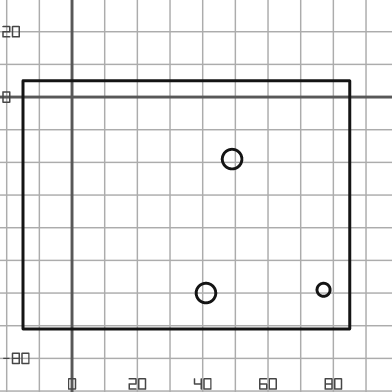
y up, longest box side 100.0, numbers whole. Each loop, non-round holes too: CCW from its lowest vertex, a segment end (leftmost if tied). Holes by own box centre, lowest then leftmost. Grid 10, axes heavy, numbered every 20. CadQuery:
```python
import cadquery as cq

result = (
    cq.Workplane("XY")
    .moveTo(-15.0, -71.0)
    .lineTo(85.0, -71.0)
    .lineTo(85.0, 5.0)
    .lineTo(-15.0, 5.0)
    .close()
    .moveTo(41.0, -60.0)
    .circle(3.0)
    .moveTo(77.0, -59.0)
    .circle(2.0)
    .moveTo(49.0, -19.0)
    .circle(3.0)
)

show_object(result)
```